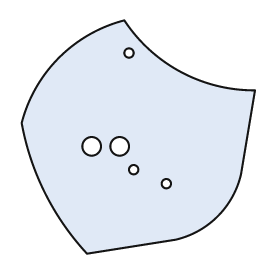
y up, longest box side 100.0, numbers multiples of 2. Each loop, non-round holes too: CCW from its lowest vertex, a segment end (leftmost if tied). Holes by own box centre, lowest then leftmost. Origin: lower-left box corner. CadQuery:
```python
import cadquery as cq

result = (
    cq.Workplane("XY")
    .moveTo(28.0, 0.0)
    .lineTo(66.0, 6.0)
    .threePointArc((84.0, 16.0), (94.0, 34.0))
    .lineTo(100.0, 70.0)
    .threePointArc((68.0, 78.0), (44.0, 100.0))
    .threePointArc((16.0, 84.0), (0.0, 56.0))
    .threePointArc((10.0, 26.0), (28.0, 0.0))
    .close()
    .moveTo(62.0, 30.0)
    .circle(2.0)
    .moveTo(48.0, 36.0)
    .circle(2.0)
    .moveTo(30.0, 46.0)
    .circle(4.0)
    .moveTo(42.0, 46.0)
    .circle(4.0)
    .moveTo(46.0, 86.0)
    .circle(2.0)
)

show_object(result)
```